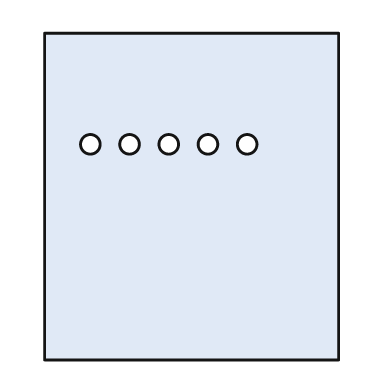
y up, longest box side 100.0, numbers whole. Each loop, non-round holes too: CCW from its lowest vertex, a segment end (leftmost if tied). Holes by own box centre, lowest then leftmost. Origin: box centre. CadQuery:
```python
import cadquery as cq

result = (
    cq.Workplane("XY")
    .moveTo(-45.0, -50.0)
    .lineTo(45.0, -50.0)
    .lineTo(45.0, 50.0)
    .lineTo(-45.0, 50.0)
    .close()
    .moveTo(-31.0, 16.0)
    .circle(3.0)
    .moveTo(-19.0, 16.0)
    .circle(3.0)
    .moveTo(-7.0, 16.0)
    .circle(3.0)
    .moveTo(5.0, 16.0)
    .circle(3.0)
    .moveTo(17.0, 16.0)
    .circle(3.0)
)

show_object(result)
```